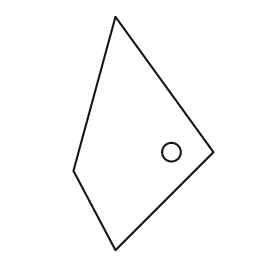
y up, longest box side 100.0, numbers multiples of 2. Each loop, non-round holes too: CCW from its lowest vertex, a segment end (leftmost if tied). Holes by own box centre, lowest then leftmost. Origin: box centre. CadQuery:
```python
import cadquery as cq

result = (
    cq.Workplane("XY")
    .moveTo(-12.0, -50.0)
    .lineTo(30.0, -8.0)
    .lineTo(-12.0, 50.0)
    .lineTo(-30.0, -16.0)
    .close()
    .moveTo(12.0, -8.0)
    .circle(4.0)
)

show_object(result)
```